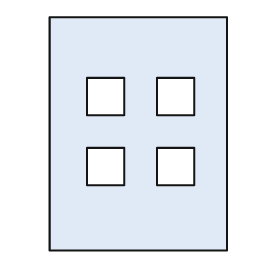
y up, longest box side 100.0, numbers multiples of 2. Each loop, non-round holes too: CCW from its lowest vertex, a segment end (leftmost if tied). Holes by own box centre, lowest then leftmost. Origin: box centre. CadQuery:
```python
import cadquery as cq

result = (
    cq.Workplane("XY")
    .moveTo(-38.0, -50.0)
    .lineTo(38.0, -50.0)
    .lineTo(38.0, 50.0)
    .lineTo(-38.0, 50.0)
    .close()
    .moveTo(-22.0, -22.0)
    .lineTo(-6.0, -22.0)
    .lineTo(-6.0, -6.0)
    .lineTo(-22.0, -6.0)
    .close()
    .moveTo(8.0, -22.0)
    .lineTo(24.0, -22.0)
    .lineTo(24.0, -6.0)
    .lineTo(8.0, -6.0)
    .close()
    .moveTo(-22.0, 8.0)
    .lineTo(-6.0, 8.0)
    .lineTo(-6.0, 24.0)
    .lineTo(-22.0, 24.0)
    .close()
    .moveTo(8.0, 8.0)
    .lineTo(24.0, 8.0)
    .lineTo(24.0, 24.0)
    .lineTo(8.0, 24.0)
    .close()
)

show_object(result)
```